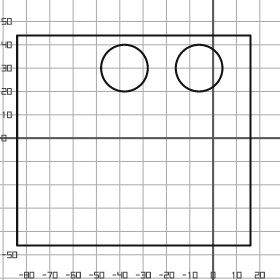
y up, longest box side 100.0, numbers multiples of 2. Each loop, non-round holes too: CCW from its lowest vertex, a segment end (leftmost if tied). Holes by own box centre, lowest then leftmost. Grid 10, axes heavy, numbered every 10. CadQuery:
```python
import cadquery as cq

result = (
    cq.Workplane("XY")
    .moveTo(-84.0, -46.0)
    .lineTo(16.0, -46.0)
    .lineTo(16.0, 44.0)
    .lineTo(-84.0, 44.0)
    .close()
    .moveTo(-38.0, 30.0)
    .circle(10.0)
    .moveTo(-6.0, 30.0)
    .circle(10.0)
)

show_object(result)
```